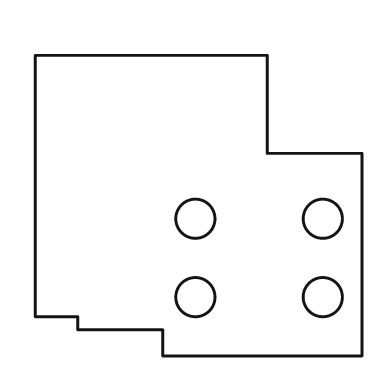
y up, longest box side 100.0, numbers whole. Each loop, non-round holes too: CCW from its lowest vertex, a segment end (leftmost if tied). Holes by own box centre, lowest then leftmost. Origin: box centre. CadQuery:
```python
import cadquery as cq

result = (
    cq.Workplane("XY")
    .moveTo(-11.0, -46.0)
    .lineTo(50.0, -46.0)
    .lineTo(50.0, 16.0)
    .lineTo(21.0, 16.0)
    .lineTo(21.0, 46.0)
    .lineTo(-50.0, 46.0)
    .lineTo(-50.0, -34.0)
    .lineTo(-37.0, -34.0)
    .lineTo(-37.0, -38.0)
    .lineTo(-11.0, -38.0)
    .close()
    .moveTo(-1.0, -28.0)
    .circle(6.0)
    .moveTo(38.0, -28.0)
    .circle(6.0)
    .moveTo(-1.0, -4.0)
    .circle(6.0)
    .moveTo(38.0, -4.0)
    .circle(6.0)
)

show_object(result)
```